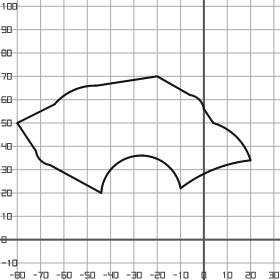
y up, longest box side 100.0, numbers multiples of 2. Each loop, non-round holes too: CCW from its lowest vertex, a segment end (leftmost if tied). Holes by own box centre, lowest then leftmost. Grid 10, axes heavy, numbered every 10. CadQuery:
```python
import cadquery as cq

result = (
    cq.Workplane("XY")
    .moveTo(-44.0, 20.0)
    .threePointArc((-28.0, 36.0), (-10.0, 22.0))
    .threePointArc((4.0, 30.0), (20.0, 34.0))
    .threePointArc((14.0, 44.0), (4.0, 50.0))
    .lineTo(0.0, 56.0)
    .threePointArc((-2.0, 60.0), (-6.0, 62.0))
    .lineTo(-20.0, 70.0)
    .lineTo(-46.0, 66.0)
    .threePointArc((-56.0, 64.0), (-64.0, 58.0))
    .lineTo(-80.0, 50.0)
    .lineTo(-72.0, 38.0)
    .threePointArc((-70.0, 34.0), (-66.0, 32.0))
    .close()
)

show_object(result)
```